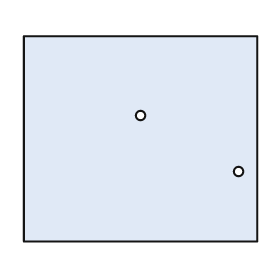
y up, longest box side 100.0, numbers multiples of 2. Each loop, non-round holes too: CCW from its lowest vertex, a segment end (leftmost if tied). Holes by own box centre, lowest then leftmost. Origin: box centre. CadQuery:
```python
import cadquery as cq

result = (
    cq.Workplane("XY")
    .moveTo(-50.0, -44.0)
    .lineTo(50.0, -44.0)
    .lineTo(50.0, 44.0)
    .lineTo(-50.0, 44.0)
    .close()
    .moveTo(42.0, -14.0)
    .circle(2.0)
    .moveTo(0.0, 10.0)
    .circle(2.0)
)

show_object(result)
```